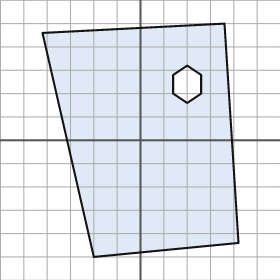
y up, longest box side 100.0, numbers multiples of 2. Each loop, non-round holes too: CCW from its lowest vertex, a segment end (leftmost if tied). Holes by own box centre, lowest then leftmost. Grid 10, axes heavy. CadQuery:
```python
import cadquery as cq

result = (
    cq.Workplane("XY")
    .moveTo(-20.0, -50.0)
    .lineTo(42.0, -44.0)
    .lineTo(36.0, 50.0)
    .lineTo(-42.0, 46.0)
    .close()
    .moveTo(20.0, 16.0)
    .lineTo(26.0, 20.0)
    .lineTo(26.0, 28.0)
    .lineTo(20.0, 32.0)
    .lineTo(14.0, 28.0)
    .lineTo(14.0, 20.0)
    .close()
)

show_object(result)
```